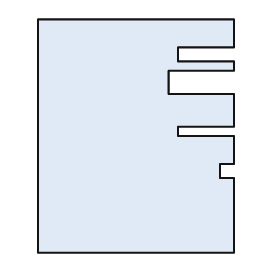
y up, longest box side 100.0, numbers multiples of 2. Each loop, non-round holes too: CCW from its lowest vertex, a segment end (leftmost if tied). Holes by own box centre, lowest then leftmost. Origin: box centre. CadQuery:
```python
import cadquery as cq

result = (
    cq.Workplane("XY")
    .moveTo(-42.0, -50.0)
    .lineTo(42.0, -50.0)
    .lineTo(42.0, -18.0)
    .lineTo(36.0, -18.0)
    .lineTo(36.0, -12.0)
    .lineTo(42.0, -12.0)
    .lineTo(42.0, 0.0)
    .lineTo(18.0, 0.0)
    .lineTo(18.0, 4.0)
    .lineTo(42.0, 4.0)
    .lineTo(42.0, 18.0)
    .lineTo(14.0, 18.0)
    .lineTo(14.0, 28.0)
    .lineTo(42.0, 28.0)
    .lineTo(42.0, 32.0)
    .lineTo(18.0, 32.0)
    .lineTo(18.0, 38.0)
    .lineTo(42.0, 38.0)
    .lineTo(42.0, 50.0)
    .lineTo(-42.0, 50.0)
    .close()
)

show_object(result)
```